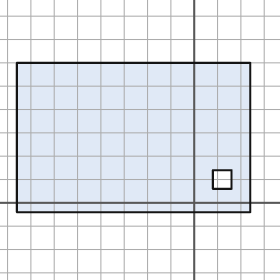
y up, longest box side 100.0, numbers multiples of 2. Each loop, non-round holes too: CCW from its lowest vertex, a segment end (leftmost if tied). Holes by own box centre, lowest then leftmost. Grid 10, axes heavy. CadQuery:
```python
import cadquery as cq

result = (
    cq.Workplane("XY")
    .moveTo(-76.0, -4.0)
    .lineTo(24.0, -4.0)
    .lineTo(24.0, 60.0)
    .lineTo(-76.0, 60.0)
    .close()
    .moveTo(8.0, 6.0)
    .lineTo(16.0, 6.0)
    .lineTo(16.0, 14.0)
    .lineTo(8.0, 14.0)
    .close()
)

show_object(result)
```